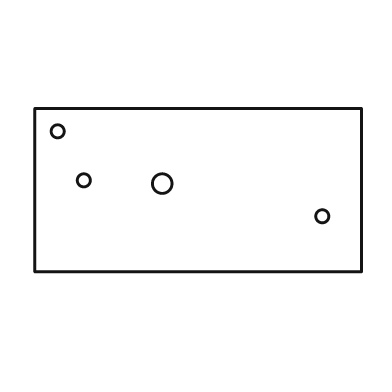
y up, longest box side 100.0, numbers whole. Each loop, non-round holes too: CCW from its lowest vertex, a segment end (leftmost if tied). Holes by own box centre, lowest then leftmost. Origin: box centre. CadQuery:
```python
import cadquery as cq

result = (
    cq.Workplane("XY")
    .moveTo(-50.0, -25.0)
    .lineTo(50.0, -25.0)
    .lineTo(50.0, 25.0)
    .lineTo(-50.0, 25.0)
    .close()
    .moveTo(38.0, -8.0)
    .circle(2.0)
    .moveTo(-11.0, 2.0)
    .circle(3.0)
    .moveTo(-35.0, 3.0)
    .circle(2.0)
    .moveTo(-43.0, 18.0)
    .circle(2.0)
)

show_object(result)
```